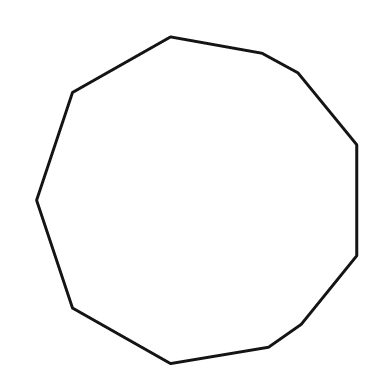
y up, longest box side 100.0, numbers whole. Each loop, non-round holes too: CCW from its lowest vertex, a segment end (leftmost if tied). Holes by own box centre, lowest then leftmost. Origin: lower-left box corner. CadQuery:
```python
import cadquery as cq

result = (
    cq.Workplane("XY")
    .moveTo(41.0, 0.0)
    .lineTo(71.0, 5.0)
    .lineTo(81.0, 12.0)
    .lineTo(98.0, 33.0)
    .lineTo(98.0, 67.0)
    .lineTo(80.0, 89.0)
    .lineTo(69.0, 95.0)
    .lineTo(41.0, 100.0)
    .lineTo(11.0, 83.0)
    .lineTo(0.0, 50.0)
    .lineTo(11.0, 17.0)
    .close()
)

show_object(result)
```